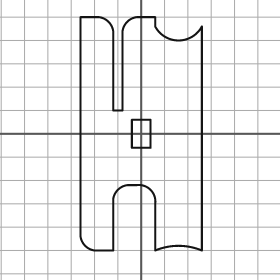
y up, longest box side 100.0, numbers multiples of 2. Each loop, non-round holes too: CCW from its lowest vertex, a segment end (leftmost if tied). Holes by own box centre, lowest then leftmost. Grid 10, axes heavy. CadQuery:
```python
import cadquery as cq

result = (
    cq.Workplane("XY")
    .moveTo(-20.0, -50.0)
    .lineTo(-12.0, -50.0)
    .lineTo(-12.0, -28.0)
    .threePointArc((-10.0, -24.0), (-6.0, -22.0))
    .lineTo(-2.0, -22.0)
    .threePointArc((4.0, -24.0), (6.0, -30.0))
    .lineTo(6.0, -50.0)
    .threePointArc((16.0, -48.0), (26.0, -50.0))
    .lineTo(26.0, 46.0)
    .threePointArc((16.0, 40.0), (6.0, 46.0))
    .lineTo(6.0, 50.0)
    .lineTo(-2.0, 50.0)
    .threePointArc((-6.0, 48.0), (-8.0, 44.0))
    .lineTo(-8.0, 10.0)
    .lineTo(-12.0, 10.0)
    .lineTo(-12.0, 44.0)
    .threePointArc((-14.0, 48.0), (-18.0, 50.0))
    .lineTo(-26.0, 50.0)
    .lineTo(-26.0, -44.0)
    .threePointArc((-24.0, -48.0), (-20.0, -50.0))
    .close()
    .moveTo(-4.0, -6.0)
    .lineTo(4.0, -6.0)
    .lineTo(4.0, 6.0)
    .lineTo(-4.0, 6.0)
    .close()
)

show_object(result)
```